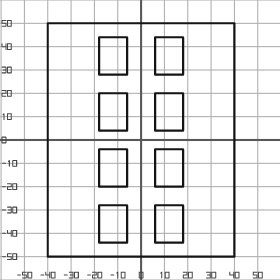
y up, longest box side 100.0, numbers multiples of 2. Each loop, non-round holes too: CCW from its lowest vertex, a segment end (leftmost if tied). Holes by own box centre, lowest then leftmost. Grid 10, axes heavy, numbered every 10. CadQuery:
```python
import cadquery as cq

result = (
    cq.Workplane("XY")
    .moveTo(-40.0, -50.0)
    .lineTo(40.0, -50.0)
    .lineTo(40.0, 50.0)
    .lineTo(-40.0, 50.0)
    .close()
    .moveTo(-18.0, -44.0)
    .lineTo(-6.0, -44.0)
    .lineTo(-6.0, -28.0)
    .lineTo(-18.0, -28.0)
    .close()
    .moveTo(6.0, -44.0)
    .lineTo(18.0, -44.0)
    .lineTo(18.0, -28.0)
    .lineTo(6.0, -28.0)
    .close()
    .moveTo(-18.0, -20.0)
    .lineTo(-6.0, -20.0)
    .lineTo(-6.0, -4.0)
    .lineTo(-18.0, -4.0)
    .close()
    .moveTo(6.0, -20.0)
    .lineTo(18.0, -20.0)
    .lineTo(18.0, -4.0)
    .lineTo(6.0, -4.0)
    .close()
    .moveTo(-18.0, 4.0)
    .lineTo(-6.0, 4.0)
    .lineTo(-6.0, 20.0)
    .lineTo(-18.0, 20.0)
    .close()
    .moveTo(6.0, 4.0)
    .lineTo(18.0, 4.0)
    .lineTo(18.0, 20.0)
    .lineTo(6.0, 20.0)
    .close()
    .moveTo(-18.0, 28.0)
    .lineTo(-6.0, 28.0)
    .lineTo(-6.0, 44.0)
    .lineTo(-18.0, 44.0)
    .close()
    .moveTo(6.0, 28.0)
    .lineTo(18.0, 28.0)
    .lineTo(18.0, 44.0)
    .lineTo(6.0, 44.0)
    .close()
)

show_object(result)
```